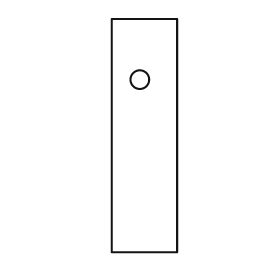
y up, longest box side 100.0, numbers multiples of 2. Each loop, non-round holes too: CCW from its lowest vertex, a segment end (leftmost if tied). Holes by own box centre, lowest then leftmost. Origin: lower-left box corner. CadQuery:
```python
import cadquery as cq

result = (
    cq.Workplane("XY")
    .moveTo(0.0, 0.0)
    .lineTo(28.0, 0.0)
    .lineTo(28.0, 100.0)
    .lineTo(0.0, 100.0)
    .close()
    .moveTo(12.0, 74.0)
    .circle(4.0)
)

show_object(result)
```